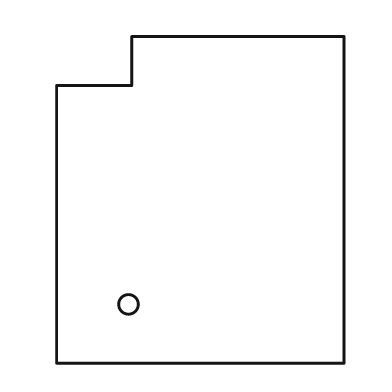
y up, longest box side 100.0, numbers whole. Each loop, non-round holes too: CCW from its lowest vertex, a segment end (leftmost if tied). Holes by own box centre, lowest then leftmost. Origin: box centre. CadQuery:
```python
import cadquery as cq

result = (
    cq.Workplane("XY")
    .moveTo(-44.0, -50.0)
    .lineTo(44.0, -50.0)
    .lineTo(44.0, 50.0)
    .lineTo(-21.0, 50.0)
    .lineTo(-21.0, 35.0)
    .lineTo(-44.0, 35.0)
    .close()
    .moveTo(-22.0, -32.0)
    .circle(3.0)
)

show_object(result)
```